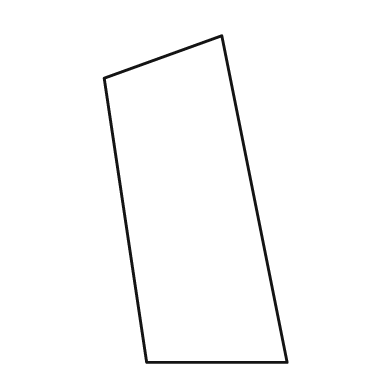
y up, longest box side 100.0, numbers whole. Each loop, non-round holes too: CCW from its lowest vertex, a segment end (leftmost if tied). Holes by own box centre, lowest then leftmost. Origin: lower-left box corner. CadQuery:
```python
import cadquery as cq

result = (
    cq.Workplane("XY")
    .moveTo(13.0, 0.0)
    .lineTo(56.0, 0.0)
    .lineTo(36.0, 100.0)
    .lineTo(0.0, 87.0)
    .close()
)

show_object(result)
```